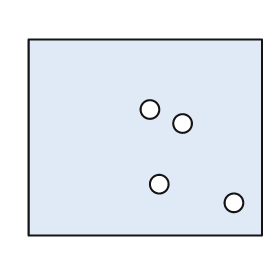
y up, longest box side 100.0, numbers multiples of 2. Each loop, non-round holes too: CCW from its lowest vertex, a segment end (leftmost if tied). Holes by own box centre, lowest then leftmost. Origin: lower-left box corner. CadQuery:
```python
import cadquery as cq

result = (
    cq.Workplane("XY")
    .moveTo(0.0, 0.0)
    .lineTo(100.0, 0.0)
    .lineTo(100.0, 84.0)
    .lineTo(0.0, 84.0)
    .close()
    .moveTo(88.0, 14.0)
    .circle(4.0)
    .moveTo(56.0, 22.0)
    .circle(4.0)
    .moveTo(66.0, 48.0)
    .circle(4.0)
    .moveTo(52.0, 54.0)
    .circle(4.0)
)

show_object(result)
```